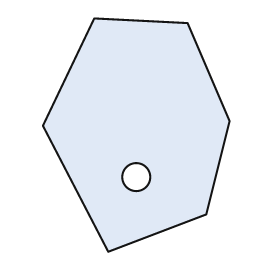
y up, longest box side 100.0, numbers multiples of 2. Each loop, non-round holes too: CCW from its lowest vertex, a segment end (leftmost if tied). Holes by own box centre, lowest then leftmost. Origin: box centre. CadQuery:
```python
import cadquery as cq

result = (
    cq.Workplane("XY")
    .moveTo(-12.0, -50.0)
    .lineTo(30.0, -34.0)
    .lineTo(40.0, 6.0)
    .lineTo(22.0, 48.0)
    .lineTo(-18.0, 50.0)
    .lineTo(-40.0, 4.0)
    .close()
    .moveTo(0.0, -18.0)
    .circle(6.0)
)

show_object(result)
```